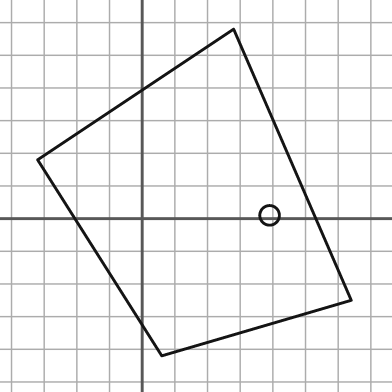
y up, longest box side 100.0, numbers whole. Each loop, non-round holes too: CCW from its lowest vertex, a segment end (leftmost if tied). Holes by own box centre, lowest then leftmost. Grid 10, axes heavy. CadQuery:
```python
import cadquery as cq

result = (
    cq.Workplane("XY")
    .moveTo(6.0, -42.0)
    .lineTo(64.0, -25.0)
    .lineTo(28.0, 58.0)
    .lineTo(-32.0, 18.0)
    .close()
    .moveTo(39.0, 1.0)
    .circle(3.0)
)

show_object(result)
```